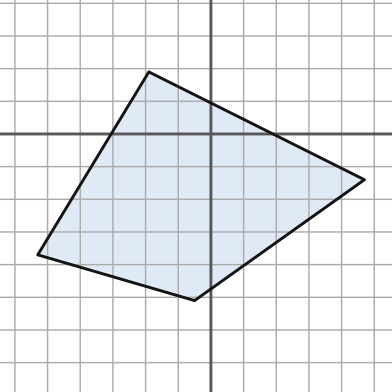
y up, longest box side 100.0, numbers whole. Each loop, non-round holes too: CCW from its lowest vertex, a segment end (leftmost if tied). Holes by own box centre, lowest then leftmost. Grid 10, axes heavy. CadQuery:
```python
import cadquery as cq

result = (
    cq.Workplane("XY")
    .moveTo(-5.0, -51.0)
    .lineTo(47.0, -14.0)
    .lineTo(-19.0, 19.0)
    .lineTo(-53.0, -37.0)
    .close()
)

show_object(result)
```